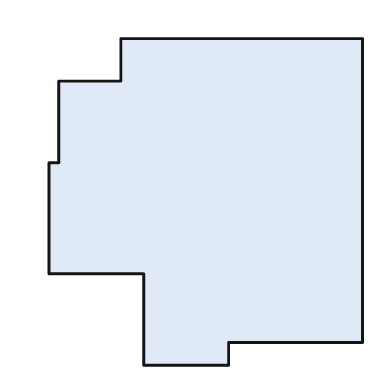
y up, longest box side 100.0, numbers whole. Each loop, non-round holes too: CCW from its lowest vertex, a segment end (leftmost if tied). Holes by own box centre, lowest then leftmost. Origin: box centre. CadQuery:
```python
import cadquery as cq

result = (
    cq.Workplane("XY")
    .moveTo(-19.0, -50.0)
    .lineTo(7.0, -50.0)
    .lineTo(7.0, -43.0)
    .lineTo(48.0, -43.0)
    .lineTo(48.0, 50.0)
    .lineTo(-26.0, 50.0)
    .lineTo(-26.0, 37.0)
    .lineTo(-45.0, 37.0)
    .lineTo(-45.0, 12.0)
    .lineTo(-48.0, 12.0)
    .lineTo(-48.0, -22.0)
    .lineTo(-19.0, -22.0)
    .close()
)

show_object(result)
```